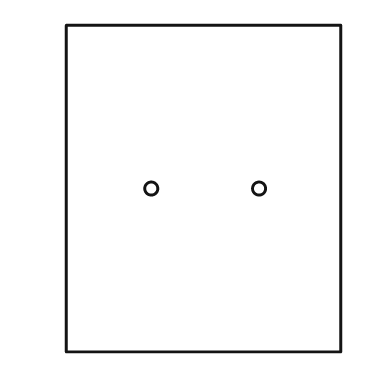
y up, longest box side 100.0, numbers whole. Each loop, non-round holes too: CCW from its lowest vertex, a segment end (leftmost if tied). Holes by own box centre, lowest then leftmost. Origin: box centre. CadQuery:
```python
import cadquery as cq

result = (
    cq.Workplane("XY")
    .moveTo(-42.0, -50.0)
    .lineTo(42.0, -50.0)
    .lineTo(42.0, 50.0)
    .lineTo(-42.0, 50.0)
    .close()
    .moveTo(-16.0, 0.0)
    .circle(2.0)
    .moveTo(17.0, 0.0)
    .circle(2.0)
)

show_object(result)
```